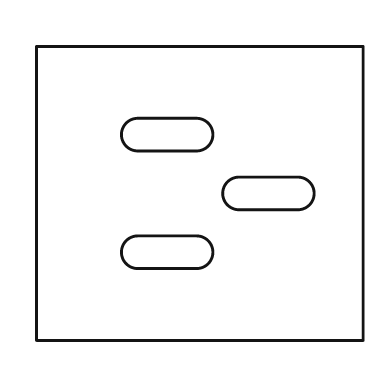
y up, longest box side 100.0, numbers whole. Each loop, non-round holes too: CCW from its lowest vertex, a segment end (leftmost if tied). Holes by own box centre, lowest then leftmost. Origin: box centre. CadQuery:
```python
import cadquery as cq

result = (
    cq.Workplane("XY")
    .moveTo(-50.0, -45.0)
    .lineTo(50.0, -45.0)
    .lineTo(50.0, 45.0)
    .lineTo(-50.0, 45.0)
    .close()
    .moveTo(-19.0, -23.0)
    .lineTo(-1.0, -23.0)
    .threePointArc((4.0, -18.0), (-1.0, -13.0))
    .lineTo(-19.0, -13.0)
    .threePointArc((-24.0, -18.0), (-19.0, -23.0))
    .close()
    .moveTo(12.0, -5.0)
    .lineTo(30.0, -5.0)
    .threePointArc((35.0, 0.0), (30.0, 5.0))
    .lineTo(12.0, 5.0)
    .threePointArc((7.0, 0.0), (12.0, -5.0))
    .close()
    .moveTo(-19.0, 13.0)
    .lineTo(-1.0, 13.0)
    .threePointArc((4.0, 18.0), (-1.0, 23.0))
    .lineTo(-19.0, 23.0)
    .threePointArc((-24.0, 18.0), (-19.0, 13.0))
    .close()
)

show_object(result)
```